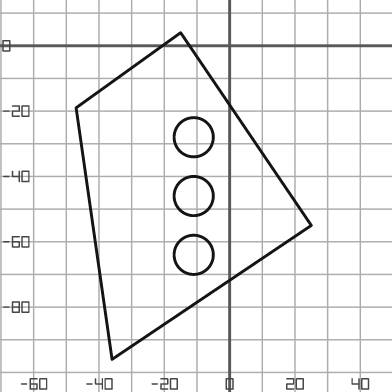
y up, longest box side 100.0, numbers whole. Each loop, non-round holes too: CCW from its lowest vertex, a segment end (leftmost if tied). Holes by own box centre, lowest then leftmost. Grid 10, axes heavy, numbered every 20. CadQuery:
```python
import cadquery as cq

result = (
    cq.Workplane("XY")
    .moveTo(-36.0, -96.0)
    .lineTo(25.0, -55.0)
    .lineTo(-15.0, 4.0)
    .lineTo(-47.0, -19.0)
    .close()
    .moveTo(-11.0, -64.0)
    .circle(6.0)
    .moveTo(-11.0, -46.0)
    .circle(6.0)
    .moveTo(-11.0, -28.0)
    .circle(6.0)
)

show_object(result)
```